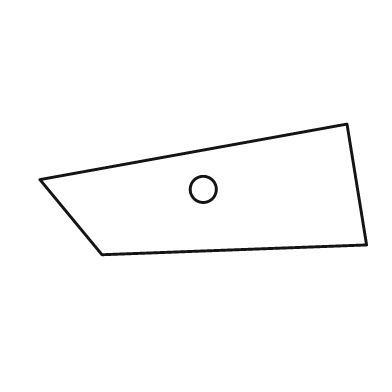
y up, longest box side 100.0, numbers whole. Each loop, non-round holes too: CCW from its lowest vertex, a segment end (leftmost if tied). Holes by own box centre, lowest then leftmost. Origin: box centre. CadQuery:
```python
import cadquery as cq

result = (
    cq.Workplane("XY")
    .moveTo(-31.0, -20.0)
    .lineTo(50.0, -17.0)
    .lineTo(44.0, 20.0)
    .lineTo(-50.0, 3.0)
    .close()
    .moveTo(0.0, 0.0)
    .circle(4.0)
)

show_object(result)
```